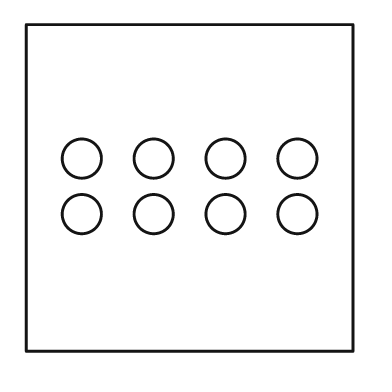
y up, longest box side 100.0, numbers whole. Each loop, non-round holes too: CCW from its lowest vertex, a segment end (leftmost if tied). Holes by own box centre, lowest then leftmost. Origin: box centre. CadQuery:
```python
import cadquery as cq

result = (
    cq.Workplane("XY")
    .moveTo(-50.0, -50.0)
    .lineTo(50.0, -50.0)
    .lineTo(50.0, 50.0)
    .lineTo(-50.0, 50.0)
    .close()
    .moveTo(-33.0, -8.0)
    .circle(6.0)
    .moveTo(-11.0, -8.0)
    .circle(6.0)
    .moveTo(11.0, -8.0)
    .circle(6.0)
    .moveTo(33.0, -8.0)
    .circle(6.0)
    .moveTo(-33.0, 9.0)
    .circle(6.0)
    .moveTo(-11.0, 9.0)
    .circle(6.0)
    .moveTo(11.0, 9.0)
    .circle(6.0)
    .moveTo(33.0, 9.0)
    .circle(6.0)
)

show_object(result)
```